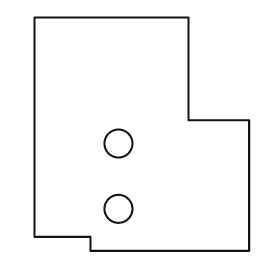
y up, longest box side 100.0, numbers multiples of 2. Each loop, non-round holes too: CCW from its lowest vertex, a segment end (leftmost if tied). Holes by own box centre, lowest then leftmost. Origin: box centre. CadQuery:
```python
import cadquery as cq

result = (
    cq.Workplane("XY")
    .moveTo(-22.0, -50.0)
    .lineTo(46.0, -50.0)
    .lineTo(46.0, 6.0)
    .lineTo(20.0, 6.0)
    .lineTo(20.0, 50.0)
    .lineTo(-46.0, 50.0)
    .lineTo(-46.0, -44.0)
    .lineTo(-22.0, -44.0)
    .close()
    .moveTo(-10.0, -32.0)
    .circle(6.0)
    .moveTo(-10.0, -4.0)
    .circle(6.0)
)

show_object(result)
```